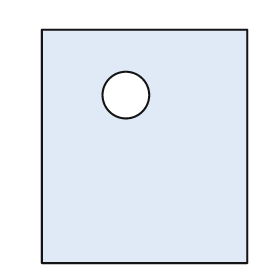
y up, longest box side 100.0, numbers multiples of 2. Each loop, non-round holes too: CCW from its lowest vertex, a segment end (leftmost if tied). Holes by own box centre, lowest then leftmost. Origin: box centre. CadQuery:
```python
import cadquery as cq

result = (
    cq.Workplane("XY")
    .moveTo(-44.0, -50.0)
    .lineTo(44.0, -50.0)
    .lineTo(44.0, 50.0)
    .lineTo(-44.0, 50.0)
    .close()
    .moveTo(-8.0, 22.0)
    .circle(10.0)
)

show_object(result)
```